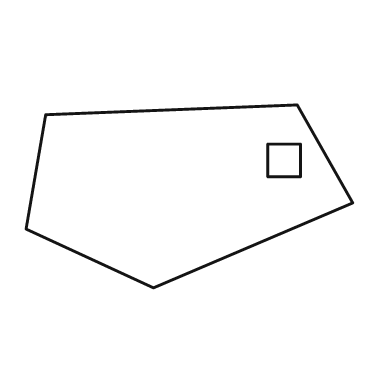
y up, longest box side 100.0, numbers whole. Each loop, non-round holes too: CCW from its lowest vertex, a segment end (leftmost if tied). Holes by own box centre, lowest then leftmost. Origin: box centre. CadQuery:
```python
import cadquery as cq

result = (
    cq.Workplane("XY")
    .moveTo(-11.0, -28.0)
    .lineTo(50.0, -2.0)
    .lineTo(33.0, 28.0)
    .lineTo(-44.0, 25.0)
    .lineTo(-50.0, -10.0)
    .close()
    .moveTo(24.0, 6.0)
    .lineTo(34.0, 6.0)
    .lineTo(34.0, 16.0)
    .lineTo(24.0, 16.0)
    .close()
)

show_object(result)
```